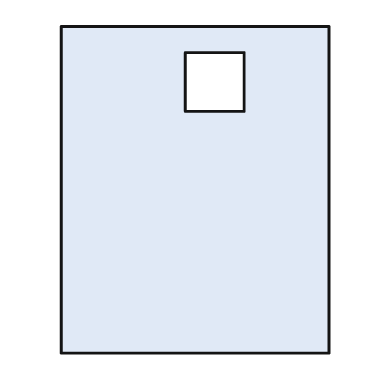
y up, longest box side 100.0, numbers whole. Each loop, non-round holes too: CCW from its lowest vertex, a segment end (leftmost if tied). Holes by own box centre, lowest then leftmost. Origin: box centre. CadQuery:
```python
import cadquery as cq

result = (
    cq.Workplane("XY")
    .moveTo(-41.0, -50.0)
    .lineTo(41.0, -50.0)
    .lineTo(41.0, 50.0)
    .lineTo(-41.0, 50.0)
    .close()
    .moveTo(-3.0, 24.0)
    .lineTo(15.0, 24.0)
    .lineTo(15.0, 42.0)
    .lineTo(-3.0, 42.0)
    .close()
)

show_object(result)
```